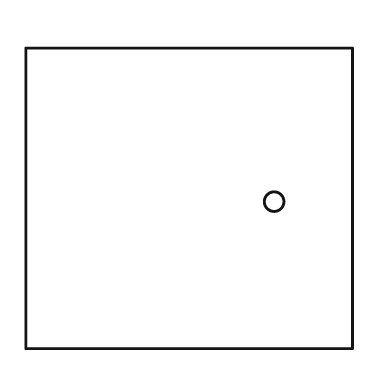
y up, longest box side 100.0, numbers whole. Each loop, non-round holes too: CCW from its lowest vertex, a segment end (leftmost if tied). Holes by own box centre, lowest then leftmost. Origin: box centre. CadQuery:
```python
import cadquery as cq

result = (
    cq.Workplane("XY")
    .moveTo(-50.0, -46.0)
    .lineTo(50.0, -46.0)
    .lineTo(50.0, 46.0)
    .lineTo(-50.0, 46.0)
    .close()
    .moveTo(26.0, -1.0)
    .circle(3.0)
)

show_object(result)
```